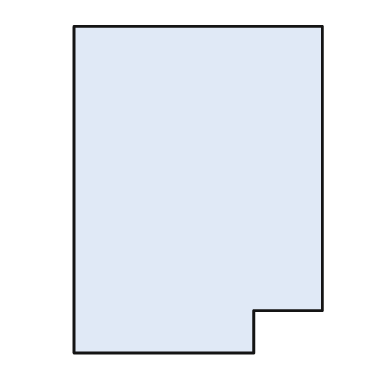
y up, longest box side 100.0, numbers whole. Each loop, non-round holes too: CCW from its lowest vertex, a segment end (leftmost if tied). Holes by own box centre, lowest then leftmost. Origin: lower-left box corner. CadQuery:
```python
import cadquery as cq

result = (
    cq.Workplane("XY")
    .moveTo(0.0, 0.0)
    .lineTo(55.0, 0.0)
    .lineTo(55.0, 13.0)
    .lineTo(76.0, 13.0)
    .lineTo(76.0, 100.0)
    .lineTo(0.0, 100.0)
    .close()
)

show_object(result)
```